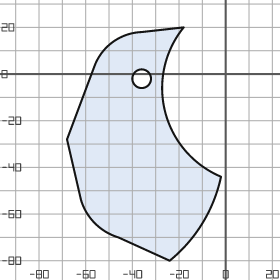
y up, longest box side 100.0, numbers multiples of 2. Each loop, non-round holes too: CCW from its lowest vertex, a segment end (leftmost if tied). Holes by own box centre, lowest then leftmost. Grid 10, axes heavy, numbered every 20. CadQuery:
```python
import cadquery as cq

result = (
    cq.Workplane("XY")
    .moveTo(-24.0, -80.0)
    .threePointArc((-10.0, -64.0), (-2.0, -44.0))
    .threePointArc((-26.0, -16.0), (-18.0, 20.0))
    .lineTo(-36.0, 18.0)
    .threePointArc((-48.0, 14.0), (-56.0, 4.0))
    .lineTo(-68.0, -28.0)
    .lineTo(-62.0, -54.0)
    .threePointArc((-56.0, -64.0), (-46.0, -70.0))
    .close()
    .moveTo(-36.0, -2.0)
    .circle(4.0)
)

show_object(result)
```